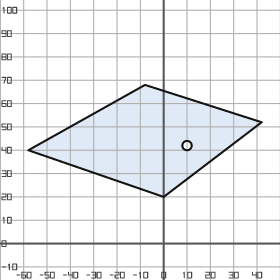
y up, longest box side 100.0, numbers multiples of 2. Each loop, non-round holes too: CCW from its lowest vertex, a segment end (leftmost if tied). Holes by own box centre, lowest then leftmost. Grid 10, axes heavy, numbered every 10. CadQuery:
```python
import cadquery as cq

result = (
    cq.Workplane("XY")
    .moveTo(0.0, 20.0)
    .lineTo(42.0, 52.0)
    .lineTo(-8.0, 68.0)
    .lineTo(-58.0, 40.0)
    .close()
    .moveTo(10.0, 42.0)
    .circle(2.0)
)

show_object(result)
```